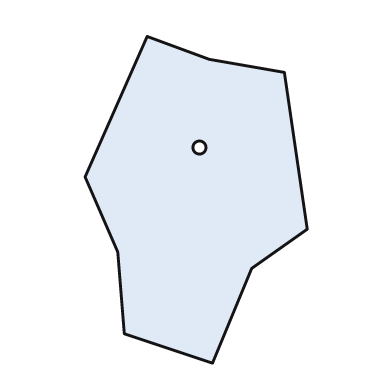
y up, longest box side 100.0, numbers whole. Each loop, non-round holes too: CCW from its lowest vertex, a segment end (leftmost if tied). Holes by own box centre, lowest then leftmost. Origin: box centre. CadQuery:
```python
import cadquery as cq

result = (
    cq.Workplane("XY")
    .moveTo(5.0, -50.0)
    .lineTo(17.0, -21.0)
    .lineTo(34.0, -9.0)
    .lineTo(27.0, 39.0)
    .lineTo(4.0, 43.0)
    .lineTo(-15.0, 50.0)
    .lineTo(-34.0, 7.0)
    .lineTo(-24.0, -16.0)
    .lineTo(-22.0, -41.0)
    .close()
    .moveTo(1.0, 16.0)
    .circle(2.0)
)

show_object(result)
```